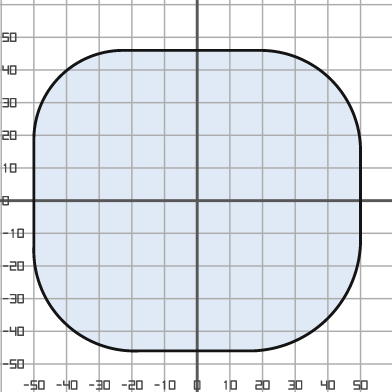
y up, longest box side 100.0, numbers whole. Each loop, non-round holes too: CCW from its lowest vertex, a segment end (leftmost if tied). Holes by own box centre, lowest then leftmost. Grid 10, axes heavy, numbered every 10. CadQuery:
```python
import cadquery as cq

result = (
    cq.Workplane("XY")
    .moveTo(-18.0, -46.0)
    .lineTo(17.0, -46.0)
    .threePointArc((40.0, -36.0), (50.0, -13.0))
    .lineTo(50.0, 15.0)
    .threePointArc((41.0, 37.0), (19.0, 46.0))
    .lineTo(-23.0, 46.0)
    .threePointArc((-42.0, 38.0), (-50.0, 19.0))
    .lineTo(-50.0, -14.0)
    .threePointArc((-41.0, -37.0), (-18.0, -46.0))
    .close()
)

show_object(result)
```